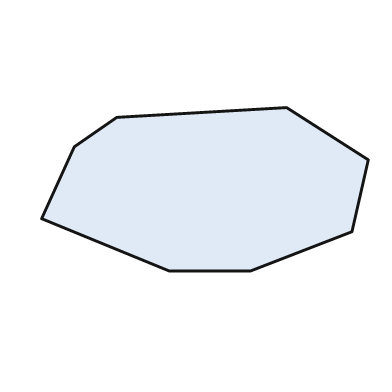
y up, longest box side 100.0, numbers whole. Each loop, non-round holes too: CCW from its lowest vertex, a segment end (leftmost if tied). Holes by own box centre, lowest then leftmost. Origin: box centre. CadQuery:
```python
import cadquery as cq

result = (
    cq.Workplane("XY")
    .moveTo(-11.0, -25.0)
    .lineTo(14.0, -25.0)
    .lineTo(45.0, -13.0)
    .lineTo(50.0, 9.0)
    .lineTo(25.0, 25.0)
    .lineTo(-27.0, 22.0)
    .lineTo(-40.0, 13.0)
    .lineTo(-50.0, -9.0)
    .close()
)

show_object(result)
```